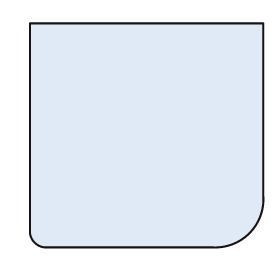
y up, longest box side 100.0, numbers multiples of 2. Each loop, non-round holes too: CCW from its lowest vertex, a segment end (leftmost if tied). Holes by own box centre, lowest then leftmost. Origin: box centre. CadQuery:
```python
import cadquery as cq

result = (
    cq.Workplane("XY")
    .moveTo(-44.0, -48.0)
    .lineTo(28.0, -48.0)
    .threePointArc((44.0, -42.0), (50.0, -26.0))
    .lineTo(50.0, 48.0)
    .lineTo(-50.0, 48.0)
    .lineTo(-50.0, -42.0)
    .threePointArc((-48.0, -46.0), (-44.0, -48.0))
    .close()
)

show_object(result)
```